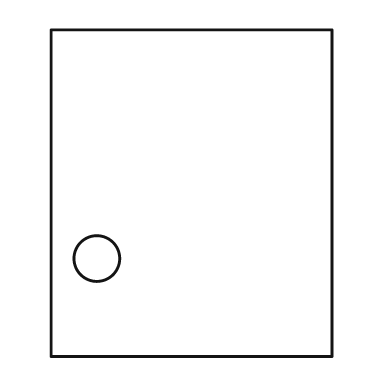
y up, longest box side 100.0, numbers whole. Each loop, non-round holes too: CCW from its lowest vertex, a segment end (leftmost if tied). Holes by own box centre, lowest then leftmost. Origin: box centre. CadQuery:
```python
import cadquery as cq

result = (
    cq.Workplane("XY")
    .moveTo(-43.0, -50.0)
    .lineTo(43.0, -50.0)
    .lineTo(43.0, 50.0)
    .lineTo(-43.0, 50.0)
    .close()
    .moveTo(-29.0, -20.0)
    .circle(7.0)
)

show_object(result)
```